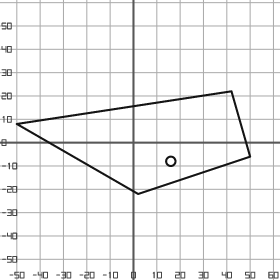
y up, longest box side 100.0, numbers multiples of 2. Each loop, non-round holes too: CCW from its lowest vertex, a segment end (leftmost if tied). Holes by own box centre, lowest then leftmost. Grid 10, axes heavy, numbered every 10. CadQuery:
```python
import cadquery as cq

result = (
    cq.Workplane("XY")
    .moveTo(2.0, -22.0)
    .lineTo(50.0, -6.0)
    .lineTo(42.0, 22.0)
    .lineTo(-50.0, 8.0)
    .close()
    .moveTo(16.0, -8.0)
    .circle(2.0)
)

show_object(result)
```